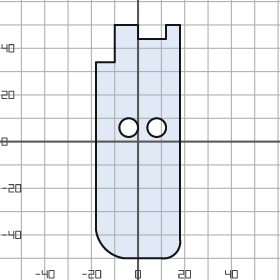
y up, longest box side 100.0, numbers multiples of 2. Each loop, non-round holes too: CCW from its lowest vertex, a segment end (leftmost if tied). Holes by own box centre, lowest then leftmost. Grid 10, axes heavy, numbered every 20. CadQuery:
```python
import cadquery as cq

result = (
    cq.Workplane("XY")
    .moveTo(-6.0, -50.0)
    .lineTo(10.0, -50.0)
    .threePointArc((16.0, -48.0), (18.0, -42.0))
    .lineTo(18.0, 50.0)
    .lineTo(12.0, 50.0)
    .lineTo(12.0, 44.0)
    .lineTo(0.0, 44.0)
    .lineTo(0.0, 50.0)
    .lineTo(-10.0, 50.0)
    .lineTo(-10.0, 34.0)
    .lineTo(-18.0, 34.0)
    .lineTo(-18.0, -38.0)
    .threePointArc((-14.0, -46.0), (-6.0, -50.0))
    .close()
    .moveTo(-4.0, 6.0)
    .circle(4.0)
    .moveTo(8.0, 6.0)
    .circle(4.0)
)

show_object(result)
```